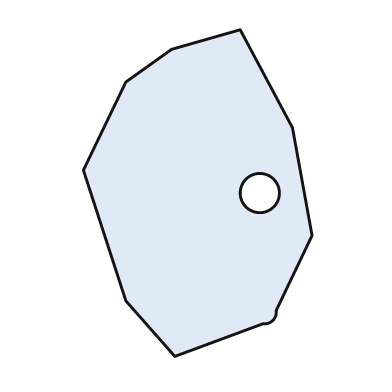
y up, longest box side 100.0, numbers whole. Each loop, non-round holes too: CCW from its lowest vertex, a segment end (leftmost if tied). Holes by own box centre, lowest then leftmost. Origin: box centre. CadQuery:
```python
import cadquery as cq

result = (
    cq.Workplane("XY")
    .moveTo(-7.0, -50.0)
    .lineTo(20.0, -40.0)
    .threePointArc((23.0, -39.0), (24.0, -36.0))
    .lineTo(35.0, -13.0)
    .lineTo(29.0, 20.0)
    .lineTo(13.0, 50.0)
    .lineTo(-8.0, 44.0)
    .lineTo(-22.0, 34.0)
    .lineTo(-35.0, 7.0)
    .lineTo(-22.0, -33.0)
    .close()
    .moveTo(19.0, 0.0)
    .circle(6.0)
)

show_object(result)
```